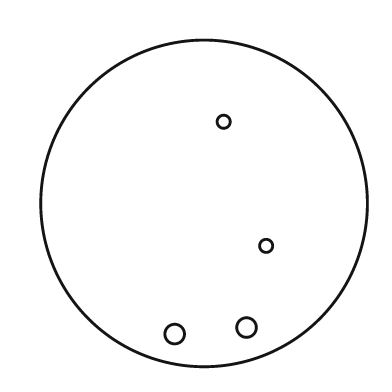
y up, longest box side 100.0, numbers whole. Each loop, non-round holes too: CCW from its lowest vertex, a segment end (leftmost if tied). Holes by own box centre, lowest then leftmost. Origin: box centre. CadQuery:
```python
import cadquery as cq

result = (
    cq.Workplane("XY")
    .moveTo(0.0, 0.0)
    .circle(50.0)
    .moveTo(-9.0, -40.0)
    .circle(3.0)
    .moveTo(13.0, -38.0)
    .circle(3.0)
    .moveTo(19.0, -13.0)
    .circle(2.0)
    .moveTo(6.0, 25.0)
    .circle(2.0)
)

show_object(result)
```